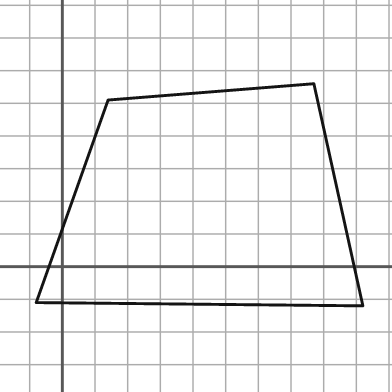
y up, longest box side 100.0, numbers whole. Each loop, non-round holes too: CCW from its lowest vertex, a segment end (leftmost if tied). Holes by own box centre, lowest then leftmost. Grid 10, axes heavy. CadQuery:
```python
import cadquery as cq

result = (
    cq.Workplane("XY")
    .moveTo(92.0, -12.0)
    .lineTo(77.0, 56.0)
    .lineTo(14.0, 51.0)
    .lineTo(-8.0, -11.0)
    .close()
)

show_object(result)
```